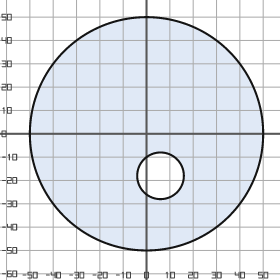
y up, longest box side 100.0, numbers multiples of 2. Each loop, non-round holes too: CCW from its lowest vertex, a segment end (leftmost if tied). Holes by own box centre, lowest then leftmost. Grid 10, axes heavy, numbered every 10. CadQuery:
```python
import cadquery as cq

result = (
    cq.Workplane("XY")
    .moveTo(0.0, 0.0)
    .circle(50.0)
    .moveTo(6.0, -18.0)
    .circle(10.0)
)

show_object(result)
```